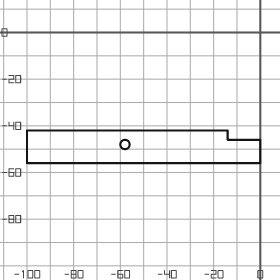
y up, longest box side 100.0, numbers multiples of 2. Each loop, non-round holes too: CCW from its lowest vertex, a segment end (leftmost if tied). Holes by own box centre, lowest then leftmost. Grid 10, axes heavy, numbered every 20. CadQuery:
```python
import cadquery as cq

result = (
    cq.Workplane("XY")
    .moveTo(-100.0, -56.0)
    .lineTo(0.0, -56.0)
    .lineTo(0.0, -46.0)
    .lineTo(-14.0, -46.0)
    .lineTo(-14.0, -42.0)
    .lineTo(-100.0, -42.0)
    .close()
    .moveTo(-58.0, -48.0)
    .circle(2.0)
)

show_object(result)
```